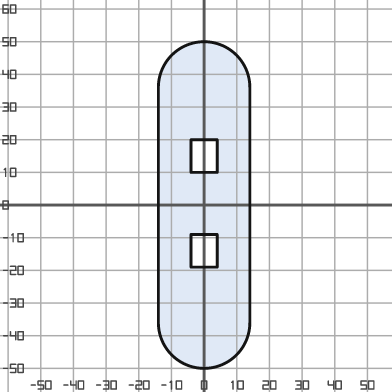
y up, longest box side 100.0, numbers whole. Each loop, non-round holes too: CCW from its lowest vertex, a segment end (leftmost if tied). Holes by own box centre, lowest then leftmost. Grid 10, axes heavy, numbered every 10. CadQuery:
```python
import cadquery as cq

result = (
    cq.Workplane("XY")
    .moveTo(-14.0, -36.0)
    .threePointArc((0.0, -50.0), (14.0, -36.0))
    .lineTo(14.0, 36.0)
    .threePointArc((0.0, 50.0), (-14.0, 36.0))
    .close()
    .moveTo(-4.0, -19.0)
    .lineTo(4.0, -19.0)
    .lineTo(4.0, -9.0)
    .lineTo(-4.0, -9.0)
    .close()
    .moveTo(-4.0, 10.0)
    .lineTo(4.0, 10.0)
    .lineTo(4.0, 20.0)
    .lineTo(-4.0, 20.0)
    .close()
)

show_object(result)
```